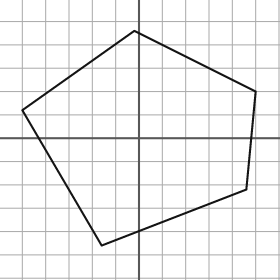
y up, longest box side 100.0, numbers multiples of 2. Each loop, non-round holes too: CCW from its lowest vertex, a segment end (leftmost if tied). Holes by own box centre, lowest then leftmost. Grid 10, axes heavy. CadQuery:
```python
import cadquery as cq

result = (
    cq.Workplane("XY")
    .moveTo(-16.0, -46.0)
    .lineTo(46.0, -22.0)
    .lineTo(50.0, 20.0)
    .lineTo(-2.0, 46.0)
    .lineTo(-50.0, 12.0)
    .close()
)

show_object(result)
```